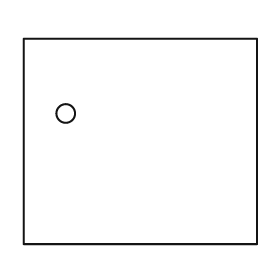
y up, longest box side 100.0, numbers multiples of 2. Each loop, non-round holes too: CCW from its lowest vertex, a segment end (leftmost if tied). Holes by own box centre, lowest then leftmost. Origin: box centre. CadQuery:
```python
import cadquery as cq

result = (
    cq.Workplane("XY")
    .moveTo(-50.0, -44.0)
    .lineTo(50.0, -44.0)
    .lineTo(50.0, 44.0)
    .lineTo(-50.0, 44.0)
    .close()
    .moveTo(-32.0, 12.0)
    .circle(4.0)
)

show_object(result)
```